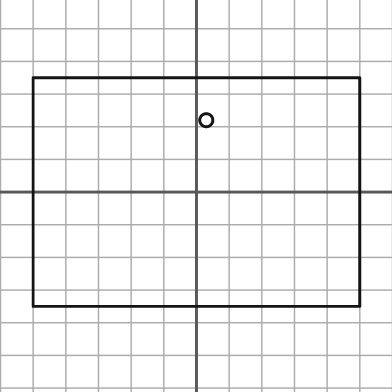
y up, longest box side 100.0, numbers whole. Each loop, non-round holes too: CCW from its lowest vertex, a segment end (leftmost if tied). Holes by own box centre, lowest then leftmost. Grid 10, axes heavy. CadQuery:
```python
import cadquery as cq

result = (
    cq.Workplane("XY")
    .moveTo(-50.0, -35.0)
    .lineTo(50.0, -35.0)
    .lineTo(50.0, 35.0)
    .lineTo(-50.0, 35.0)
    .close()
    .moveTo(3.0, 22.0)
    .circle(2.0)
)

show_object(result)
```